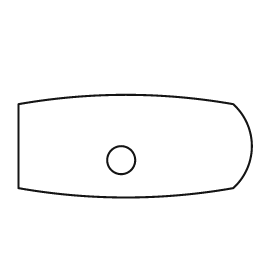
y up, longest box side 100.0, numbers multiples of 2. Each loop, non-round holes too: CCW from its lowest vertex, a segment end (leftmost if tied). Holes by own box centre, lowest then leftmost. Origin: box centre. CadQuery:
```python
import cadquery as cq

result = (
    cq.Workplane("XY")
    .moveTo(-50.0, -18.0)
    .threePointArc((-4.0, -22.0), (42.0, -18.0))
    .threePointArc((50.0, 0.0), (42.0, 18.0))
    .threePointArc((-4.0, 22.0), (-50.0, 18.0))
    .close()
    .moveTo(-6.0, -6.0)
    .circle(6.0)
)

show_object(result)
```